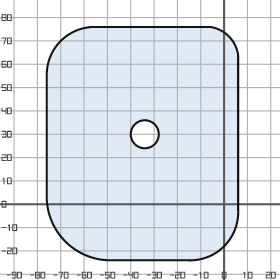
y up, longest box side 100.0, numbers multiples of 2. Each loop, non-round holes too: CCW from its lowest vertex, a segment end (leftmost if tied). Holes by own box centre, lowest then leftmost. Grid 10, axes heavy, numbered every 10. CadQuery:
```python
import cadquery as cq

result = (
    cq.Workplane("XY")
    .moveTo(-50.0, -24.0)
    .lineTo(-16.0, -24.0)
    .threePointArc((0.0, -18.0), (6.0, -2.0))
    .lineTo(6.0, 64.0)
    .threePointArc((2.0, 72.0), (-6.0, 76.0))
    .lineTo(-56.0, 76.0)
    .threePointArc((-70.0, 70.0), (-76.0, 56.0))
    .lineTo(-76.0, 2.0)
    .threePointArc((-68.0, -16.0), (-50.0, -24.0))
    .close()
    .moveTo(-34.0, 30.0)
    .circle(6.0)
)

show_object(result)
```